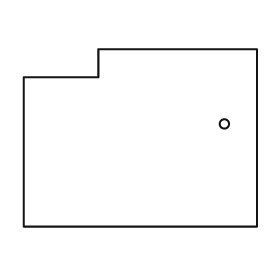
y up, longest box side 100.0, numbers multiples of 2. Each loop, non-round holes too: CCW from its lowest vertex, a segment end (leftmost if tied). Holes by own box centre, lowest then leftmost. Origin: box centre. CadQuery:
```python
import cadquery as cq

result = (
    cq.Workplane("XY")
    .moveTo(-50.0, -38.0)
    .lineTo(50.0, -38.0)
    .lineTo(50.0, 38.0)
    .lineTo(-18.0, 38.0)
    .lineTo(-18.0, 26.0)
    .lineTo(-50.0, 26.0)
    .close()
    .moveTo(36.0, 6.0)
    .circle(2.0)
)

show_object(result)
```